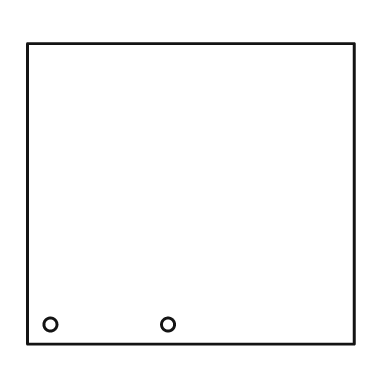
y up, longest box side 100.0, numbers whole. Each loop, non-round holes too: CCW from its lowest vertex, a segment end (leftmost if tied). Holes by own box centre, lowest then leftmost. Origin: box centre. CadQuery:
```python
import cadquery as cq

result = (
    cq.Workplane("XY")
    .moveTo(-50.0, -46.0)
    .lineTo(50.0, -46.0)
    .lineTo(50.0, 46.0)
    .lineTo(-50.0, 46.0)
    .close()
    .moveTo(-43.0, -40.0)
    .circle(2.0)
    .moveTo(-7.0, -40.0)
    .circle(2.0)
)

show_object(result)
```